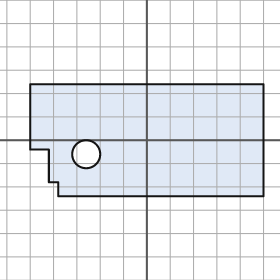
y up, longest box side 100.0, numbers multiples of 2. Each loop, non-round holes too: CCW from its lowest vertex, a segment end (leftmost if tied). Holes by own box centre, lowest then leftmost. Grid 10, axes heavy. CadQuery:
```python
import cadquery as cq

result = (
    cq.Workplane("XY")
    .moveTo(-38.0, -24.0)
    .lineTo(50.0, -24.0)
    .lineTo(50.0, 24.0)
    .lineTo(-50.0, 24.0)
    .lineTo(-50.0, -4.0)
    .lineTo(-42.0, -4.0)
    .lineTo(-42.0, -18.0)
    .lineTo(-38.0, -18.0)
    .close()
    .moveTo(-26.0, -6.0)
    .circle(6.0)
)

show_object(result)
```